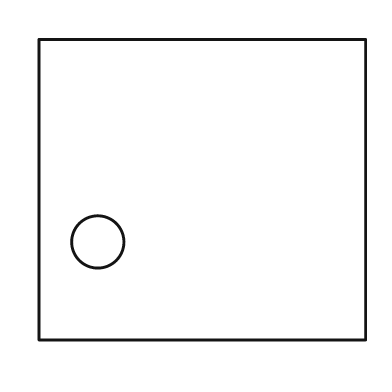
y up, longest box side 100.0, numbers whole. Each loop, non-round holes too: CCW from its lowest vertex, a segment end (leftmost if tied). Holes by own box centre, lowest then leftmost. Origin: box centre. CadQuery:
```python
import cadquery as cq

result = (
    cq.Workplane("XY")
    .moveTo(-50.0, -46.0)
    .lineTo(50.0, -46.0)
    .lineTo(50.0, 46.0)
    .lineTo(-50.0, 46.0)
    .close()
    .moveTo(-32.0, -16.0)
    .circle(8.0)
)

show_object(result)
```